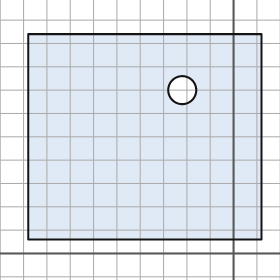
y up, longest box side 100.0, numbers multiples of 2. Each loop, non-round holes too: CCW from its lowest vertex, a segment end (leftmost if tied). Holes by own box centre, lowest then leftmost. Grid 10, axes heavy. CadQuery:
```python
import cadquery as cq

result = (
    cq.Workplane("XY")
    .moveTo(-88.0, 6.0)
    .lineTo(12.0, 6.0)
    .lineTo(12.0, 94.0)
    .lineTo(-88.0, 94.0)
    .close()
    .moveTo(-22.0, 70.0)
    .circle(6.0)
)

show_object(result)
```